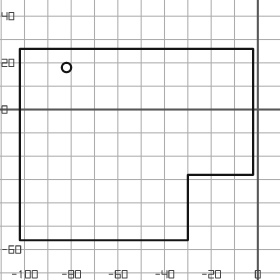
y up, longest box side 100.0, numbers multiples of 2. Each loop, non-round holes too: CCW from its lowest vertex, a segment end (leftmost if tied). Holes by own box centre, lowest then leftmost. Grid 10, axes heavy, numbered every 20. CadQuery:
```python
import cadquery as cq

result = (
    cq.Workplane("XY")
    .moveTo(-102.0, -56.0)
    .lineTo(-30.0, -56.0)
    .lineTo(-30.0, -28.0)
    .lineTo(-2.0, -28.0)
    .lineTo(-2.0, 26.0)
    .lineTo(-102.0, 26.0)
    .close()
    .moveTo(-82.0, 18.0)
    .circle(2.0)
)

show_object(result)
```